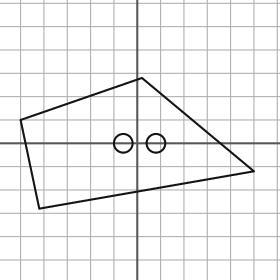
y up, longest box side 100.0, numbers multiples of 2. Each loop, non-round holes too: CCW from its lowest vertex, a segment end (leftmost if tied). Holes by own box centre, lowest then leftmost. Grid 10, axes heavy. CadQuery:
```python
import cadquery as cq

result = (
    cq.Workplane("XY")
    .moveTo(-42.0, -28.0)
    .lineTo(50.0, -12.0)
    .lineTo(2.0, 28.0)
    .lineTo(-50.0, 10.0)
    .close()
    .moveTo(-6.0, 0.0)
    .circle(4.0)
    .moveTo(8.0, 0.0)
    .circle(4.0)
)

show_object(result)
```